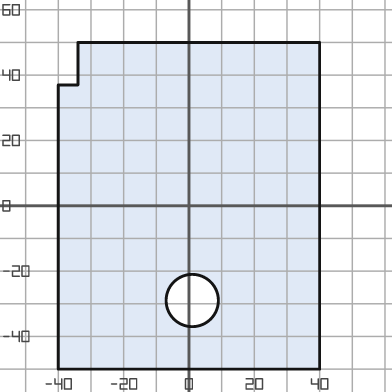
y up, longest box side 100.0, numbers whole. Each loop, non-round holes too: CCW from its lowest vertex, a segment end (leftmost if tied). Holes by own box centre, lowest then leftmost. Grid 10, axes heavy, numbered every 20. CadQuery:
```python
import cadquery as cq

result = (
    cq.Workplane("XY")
    .moveTo(-40.0, -50.0)
    .lineTo(40.0, -50.0)
    .lineTo(40.0, 50.0)
    .lineTo(-34.0, 50.0)
    .lineTo(-34.0, 37.0)
    .lineTo(-40.0, 37.0)
    .close()
    .moveTo(1.0, -29.0)
    .circle(8.0)
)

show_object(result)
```